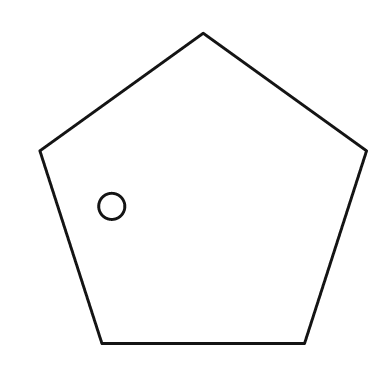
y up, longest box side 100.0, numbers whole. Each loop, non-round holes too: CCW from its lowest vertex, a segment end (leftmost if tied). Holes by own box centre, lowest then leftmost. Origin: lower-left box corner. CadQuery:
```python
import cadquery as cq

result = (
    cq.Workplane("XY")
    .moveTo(19.0, 0.0)
    .lineTo(81.0, 0.0)
    .lineTo(100.0, 59.0)
    .lineTo(50.0, 95.0)
    .lineTo(0.0, 59.0)
    .close()
    .moveTo(22.0, 42.0)
    .circle(4.0)
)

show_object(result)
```